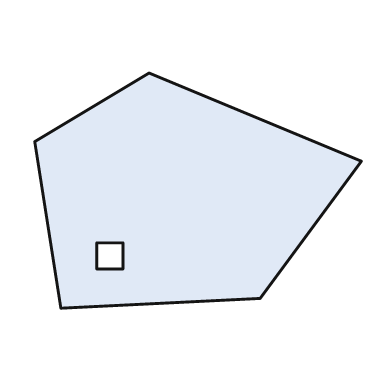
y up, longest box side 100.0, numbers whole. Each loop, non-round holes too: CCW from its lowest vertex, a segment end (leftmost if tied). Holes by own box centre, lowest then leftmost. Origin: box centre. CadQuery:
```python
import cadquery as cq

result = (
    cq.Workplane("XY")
    .moveTo(-42.0, -36.0)
    .lineTo(19.0, -33.0)
    .lineTo(50.0, 9.0)
    .lineTo(-15.0, 36.0)
    .lineTo(-50.0, 15.0)
    .close()
    .moveTo(-31.0, -24.0)
    .lineTo(-23.0, -24.0)
    .lineTo(-23.0, -16.0)
    .lineTo(-31.0, -16.0)
    .close()
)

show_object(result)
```